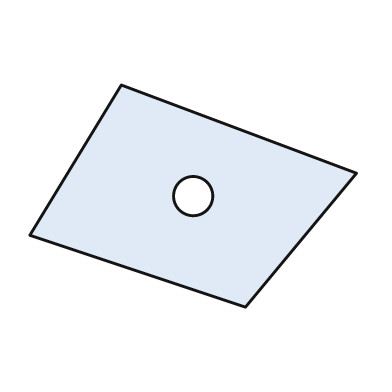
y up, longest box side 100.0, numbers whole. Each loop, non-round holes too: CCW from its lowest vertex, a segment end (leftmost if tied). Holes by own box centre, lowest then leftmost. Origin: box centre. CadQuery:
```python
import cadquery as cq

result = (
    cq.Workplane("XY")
    .moveTo(16.0, -34.0)
    .lineTo(50.0, 7.0)
    .lineTo(-22.0, 34.0)
    .lineTo(-50.0, -12.0)
    .close()
    .moveTo(0.0, 0.0)
    .circle(6.0)
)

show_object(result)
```